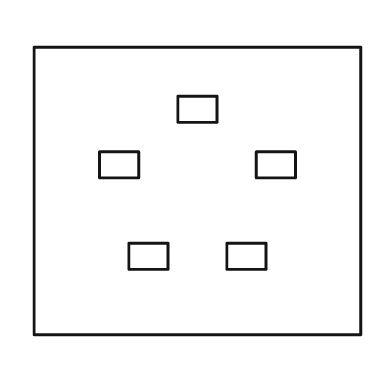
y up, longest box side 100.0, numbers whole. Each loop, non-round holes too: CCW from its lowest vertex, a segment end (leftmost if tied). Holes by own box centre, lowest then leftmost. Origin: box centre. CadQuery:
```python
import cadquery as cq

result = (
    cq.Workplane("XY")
    .moveTo(-50.0, -44.0)
    .lineTo(50.0, -44.0)
    .lineTo(50.0, 44.0)
    .lineTo(-50.0, 44.0)
    .close()
    .moveTo(-21.0, -24.0)
    .lineTo(-9.0, -24.0)
    .lineTo(-9.0, -16.0)
    .lineTo(-21.0, -16.0)
    .close()
    .moveTo(9.0, -24.0)
    .lineTo(21.0, -24.0)
    .lineTo(21.0, -16.0)
    .lineTo(9.0, -16.0)
    .close()
    .moveTo(-30.0, 4.0)
    .lineTo(-18.0, 4.0)
    .lineTo(-18.0, 12.0)
    .lineTo(-30.0, 12.0)
    .close()
    .moveTo(18.0, 4.0)
    .lineTo(30.0, 4.0)
    .lineTo(30.0, 12.0)
    .lineTo(18.0, 12.0)
    .close()
    .moveTo(-6.0, 21.0)
    .lineTo(6.0, 21.0)
    .lineTo(6.0, 29.0)
    .lineTo(-6.0, 29.0)
    .close()
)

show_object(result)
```